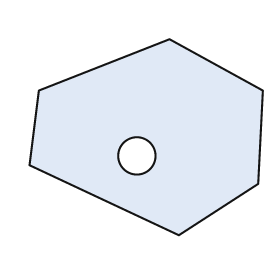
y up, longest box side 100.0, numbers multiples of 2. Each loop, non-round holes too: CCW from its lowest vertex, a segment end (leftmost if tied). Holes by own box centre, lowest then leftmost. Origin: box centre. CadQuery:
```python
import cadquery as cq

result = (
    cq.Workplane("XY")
    .moveTo(14.0, -42.0)
    .lineTo(48.0, -20.0)
    .lineTo(50.0, 20.0)
    .lineTo(10.0, 42.0)
    .lineTo(-46.0, 20.0)
    .lineTo(-50.0, -12.0)
    .close()
    .moveTo(-4.0, -8.0)
    .circle(8.0)
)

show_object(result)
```